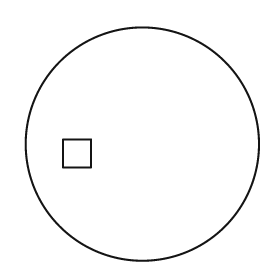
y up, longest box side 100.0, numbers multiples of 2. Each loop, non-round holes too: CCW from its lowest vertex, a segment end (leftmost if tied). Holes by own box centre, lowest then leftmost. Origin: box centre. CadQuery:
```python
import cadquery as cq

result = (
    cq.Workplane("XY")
    .moveTo(0.0, 0.0)
    .circle(50.0)
    .moveTo(-34.0, -10.0)
    .lineTo(-22.0, -10.0)
    .lineTo(-22.0, 2.0)
    .lineTo(-34.0, 2.0)
    .close()
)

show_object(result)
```